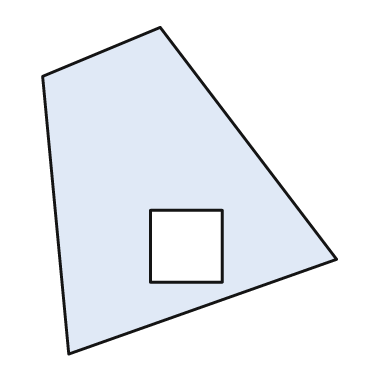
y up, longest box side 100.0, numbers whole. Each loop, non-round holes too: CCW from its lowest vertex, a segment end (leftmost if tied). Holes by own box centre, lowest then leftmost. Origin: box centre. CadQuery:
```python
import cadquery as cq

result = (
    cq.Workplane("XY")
    .moveTo(-37.0, -50.0)
    .lineTo(45.0, -21.0)
    .lineTo(-9.0, 50.0)
    .lineTo(-45.0, 35.0)
    .close()
    .moveTo(-12.0, -28.0)
    .lineTo(10.0, -28.0)
    .lineTo(10.0, -6.0)
    .lineTo(-12.0, -6.0)
    .close()
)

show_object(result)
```